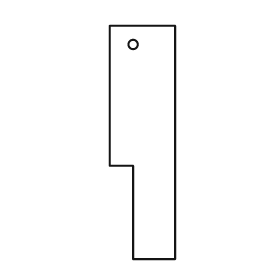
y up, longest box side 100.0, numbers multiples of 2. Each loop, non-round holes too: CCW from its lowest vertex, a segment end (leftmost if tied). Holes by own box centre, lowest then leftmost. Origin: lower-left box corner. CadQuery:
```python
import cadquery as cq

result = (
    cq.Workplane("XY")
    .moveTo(10.0, 0.0)
    .lineTo(28.0, 0.0)
    .lineTo(28.0, 100.0)
    .lineTo(0.0, 100.0)
    .lineTo(0.0, 40.0)
    .lineTo(10.0, 40.0)
    .close()
    .moveTo(10.0, 92.0)
    .circle(2.0)
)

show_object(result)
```